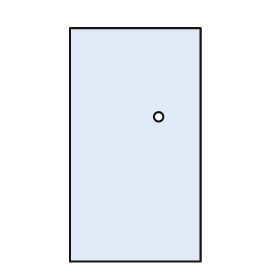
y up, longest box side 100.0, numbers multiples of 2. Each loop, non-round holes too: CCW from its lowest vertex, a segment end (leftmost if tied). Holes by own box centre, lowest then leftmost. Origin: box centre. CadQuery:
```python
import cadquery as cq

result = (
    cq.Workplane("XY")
    .moveTo(-28.0, -50.0)
    .lineTo(28.0, -50.0)
    .lineTo(28.0, 50.0)
    .lineTo(-28.0, 50.0)
    .close()
    .moveTo(10.0, 12.0)
    .circle(2.0)
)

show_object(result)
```